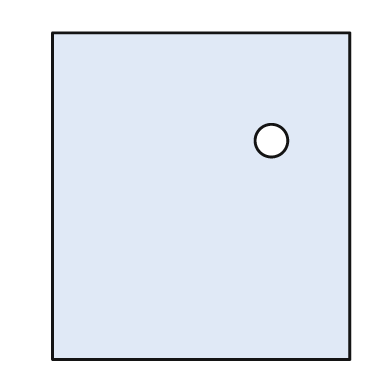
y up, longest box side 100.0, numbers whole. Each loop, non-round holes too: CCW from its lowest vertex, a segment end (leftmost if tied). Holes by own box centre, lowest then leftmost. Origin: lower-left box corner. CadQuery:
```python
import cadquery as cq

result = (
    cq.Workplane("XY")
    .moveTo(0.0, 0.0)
    .lineTo(91.0, 0.0)
    .lineTo(91.0, 100.0)
    .lineTo(0.0, 100.0)
    .close()
    .moveTo(67.0, 67.0)
    .circle(5.0)
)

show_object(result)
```